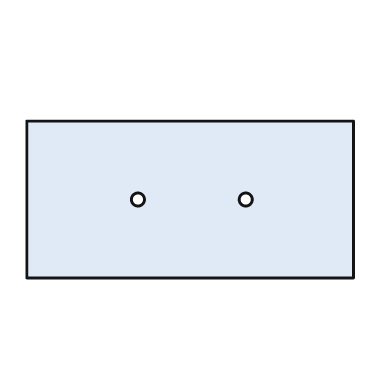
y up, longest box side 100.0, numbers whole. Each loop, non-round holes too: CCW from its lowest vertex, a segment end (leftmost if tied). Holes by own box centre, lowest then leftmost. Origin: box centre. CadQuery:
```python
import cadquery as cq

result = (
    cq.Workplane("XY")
    .moveTo(-50.0, -24.0)
    .lineTo(50.0, -24.0)
    .lineTo(50.0, 24.0)
    .lineTo(-50.0, 24.0)
    .close()
    .moveTo(-16.0, 0.0)
    .circle(2.0)
    .moveTo(17.0, 0.0)
    .circle(2.0)
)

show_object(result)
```